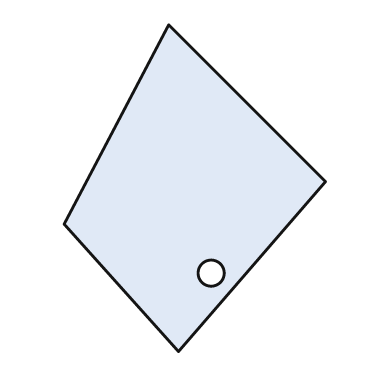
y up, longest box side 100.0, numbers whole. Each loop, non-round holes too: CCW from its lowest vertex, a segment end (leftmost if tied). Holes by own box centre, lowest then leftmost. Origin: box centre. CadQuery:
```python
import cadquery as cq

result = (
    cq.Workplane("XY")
    .moveTo(-5.0, -50.0)
    .lineTo(40.0, 2.0)
    .lineTo(-8.0, 50.0)
    .lineTo(-40.0, -11.0)
    .close()
    .moveTo(5.0, -26.0)
    .circle(4.0)
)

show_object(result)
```